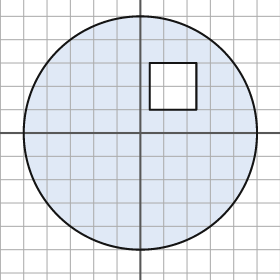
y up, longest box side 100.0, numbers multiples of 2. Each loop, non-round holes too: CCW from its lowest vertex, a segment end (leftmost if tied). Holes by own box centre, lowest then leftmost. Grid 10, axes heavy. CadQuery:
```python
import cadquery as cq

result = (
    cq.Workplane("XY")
    .moveTo(0.0, 0.0)
    .circle(50.0)
    .moveTo(4.0, 10.0)
    .lineTo(24.0, 10.0)
    .lineTo(24.0, 30.0)
    .lineTo(4.0, 30.0)
    .close()
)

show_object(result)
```